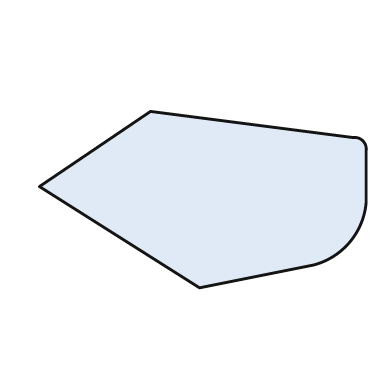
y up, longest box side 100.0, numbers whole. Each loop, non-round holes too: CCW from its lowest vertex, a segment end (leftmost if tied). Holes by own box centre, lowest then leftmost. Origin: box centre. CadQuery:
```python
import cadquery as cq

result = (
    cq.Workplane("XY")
    .moveTo(-1.0, -27.0)
    .lineTo(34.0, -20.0)
    .threePointArc((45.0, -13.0), (50.0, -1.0))
    .lineTo(50.0, 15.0)
    .threePointArc((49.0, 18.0), (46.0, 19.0))
    .lineTo(-16.0, 27.0)
    .lineTo(-50.0, 4.0)
    .close()
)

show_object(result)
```